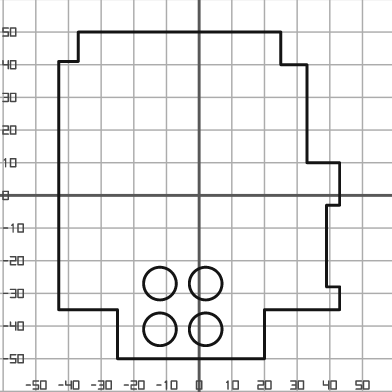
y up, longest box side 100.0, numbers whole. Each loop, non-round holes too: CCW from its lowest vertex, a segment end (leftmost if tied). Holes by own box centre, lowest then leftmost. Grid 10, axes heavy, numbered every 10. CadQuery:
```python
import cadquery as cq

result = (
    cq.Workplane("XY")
    .moveTo(-25.0, -50.0)
    .lineTo(20.0, -50.0)
    .lineTo(20.0, -35.0)
    .lineTo(43.0, -35.0)
    .lineTo(43.0, -28.0)
    .lineTo(39.0, -28.0)
    .lineTo(39.0, -3.0)
    .lineTo(43.0, -3.0)
    .lineTo(43.0, 10.0)
    .lineTo(33.0, 10.0)
    .lineTo(33.0, 40.0)
    .lineTo(25.0, 40.0)
    .lineTo(25.0, 50.0)
    .lineTo(-37.0, 50.0)
    .lineTo(-37.0, 41.0)
    .lineTo(-43.0, 41.0)
    .lineTo(-43.0, -35.0)
    .lineTo(-25.0, -35.0)
    .close()
    .moveTo(-12.0, -41.0)
    .circle(5.0)
    .moveTo(2.0, -41.0)
    .circle(5.0)
    .moveTo(-12.0, -27.0)
    .circle(5.0)
    .moveTo(2.0, -27.0)
    .circle(5.0)
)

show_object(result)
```